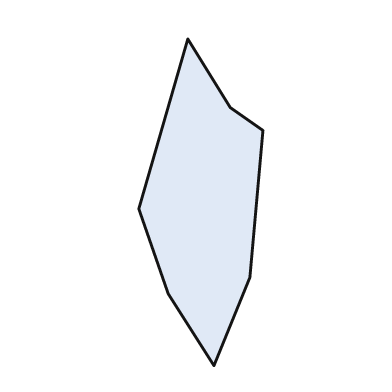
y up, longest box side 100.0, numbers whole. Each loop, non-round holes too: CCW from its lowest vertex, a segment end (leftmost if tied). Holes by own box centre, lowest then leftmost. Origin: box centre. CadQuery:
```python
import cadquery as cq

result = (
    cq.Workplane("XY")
    .moveTo(4.0, -50.0)
    .lineTo(15.0, -23.0)
    .lineTo(19.0, 22.0)
    .lineTo(9.0, 29.0)
    .lineTo(-4.0, 50.0)
    .lineTo(-19.0, -2.0)
    .lineTo(-10.0, -28.0)
    .close()
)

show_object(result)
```